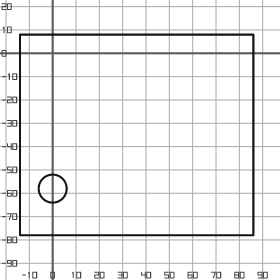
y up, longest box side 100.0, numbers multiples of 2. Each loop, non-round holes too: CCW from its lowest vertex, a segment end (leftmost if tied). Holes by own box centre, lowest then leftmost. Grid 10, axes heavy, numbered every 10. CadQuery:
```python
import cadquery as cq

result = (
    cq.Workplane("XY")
    .moveTo(-14.0, -78.0)
    .lineTo(86.0, -78.0)
    .lineTo(86.0, 8.0)
    .lineTo(-14.0, 8.0)
    .close()
    .moveTo(0.0, -58.0)
    .circle(6.0)
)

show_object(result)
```